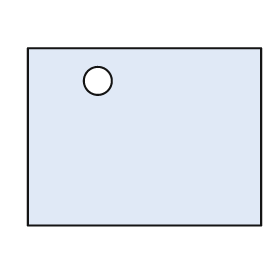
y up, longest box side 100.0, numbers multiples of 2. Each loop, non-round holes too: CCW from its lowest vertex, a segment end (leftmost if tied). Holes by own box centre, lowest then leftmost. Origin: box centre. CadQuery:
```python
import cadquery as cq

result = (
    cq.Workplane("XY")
    .moveTo(-50.0, -38.0)
    .lineTo(50.0, -38.0)
    .lineTo(50.0, 38.0)
    .lineTo(-50.0, 38.0)
    .close()
    .moveTo(-20.0, 24.0)
    .circle(6.0)
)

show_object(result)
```